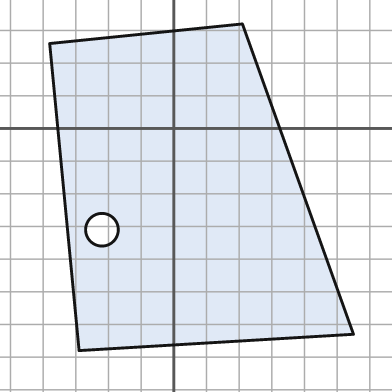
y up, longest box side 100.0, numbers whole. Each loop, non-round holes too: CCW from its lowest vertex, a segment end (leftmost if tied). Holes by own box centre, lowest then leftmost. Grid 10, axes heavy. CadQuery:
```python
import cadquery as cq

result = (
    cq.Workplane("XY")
    .moveTo(-29.0, -68.0)
    .lineTo(55.0, -63.0)
    .lineTo(21.0, 32.0)
    .lineTo(-38.0, 26.0)
    .close()
    .moveTo(-22.0, -31.0)
    .circle(5.0)
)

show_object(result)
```